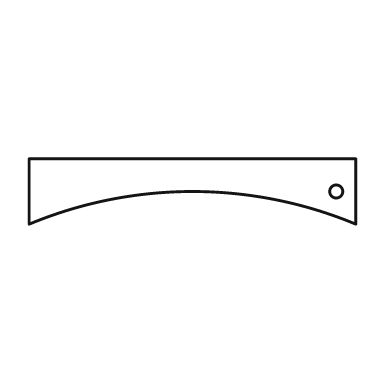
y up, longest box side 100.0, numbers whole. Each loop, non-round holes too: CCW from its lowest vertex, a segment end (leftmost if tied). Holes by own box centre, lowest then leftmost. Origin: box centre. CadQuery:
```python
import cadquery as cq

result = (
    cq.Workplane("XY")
    .moveTo(-50.0, -10.0)
    .threePointArc((0.0, 0.0), (50.0, -10.0))
    .lineTo(50.0, 10.0)
    .lineTo(-50.0, 10.0)
    .close()
    .moveTo(44.0, 0.0)
    .circle(2.0)
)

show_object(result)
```